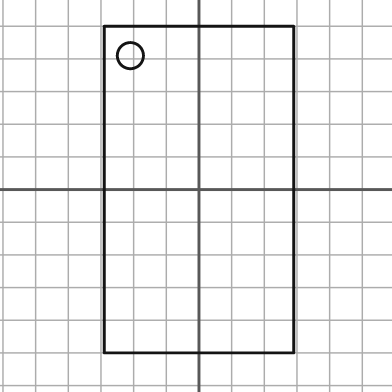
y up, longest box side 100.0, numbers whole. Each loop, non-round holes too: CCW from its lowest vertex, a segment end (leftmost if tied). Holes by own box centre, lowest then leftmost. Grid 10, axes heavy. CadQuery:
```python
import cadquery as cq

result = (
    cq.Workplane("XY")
    .moveTo(-29.0, -50.0)
    .lineTo(29.0, -50.0)
    .lineTo(29.0, 50.0)
    .lineTo(-29.0, 50.0)
    .close()
    .moveTo(-21.0, 41.0)
    .circle(4.0)
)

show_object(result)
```